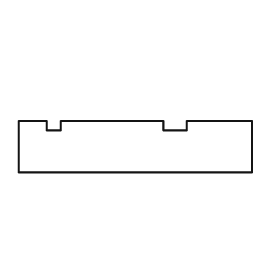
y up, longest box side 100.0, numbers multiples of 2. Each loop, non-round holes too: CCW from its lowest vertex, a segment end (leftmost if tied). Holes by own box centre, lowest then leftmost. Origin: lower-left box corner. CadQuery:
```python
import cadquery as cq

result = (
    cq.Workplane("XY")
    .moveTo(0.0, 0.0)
    .lineTo(100.0, 0.0)
    .lineTo(100.0, 22.0)
    .lineTo(72.0, 22.0)
    .lineTo(72.0, 18.0)
    .lineTo(62.0, 18.0)
    .lineTo(62.0, 22.0)
    .lineTo(18.0, 22.0)
    .lineTo(18.0, 18.0)
    .lineTo(12.0, 18.0)
    .lineTo(12.0, 22.0)
    .lineTo(0.0, 22.0)
    .close()
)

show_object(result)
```